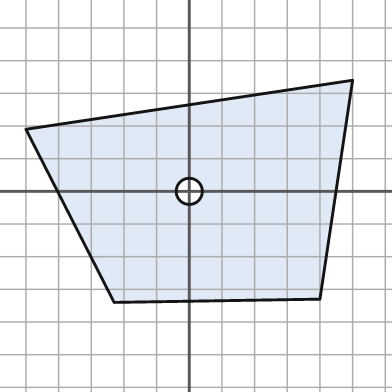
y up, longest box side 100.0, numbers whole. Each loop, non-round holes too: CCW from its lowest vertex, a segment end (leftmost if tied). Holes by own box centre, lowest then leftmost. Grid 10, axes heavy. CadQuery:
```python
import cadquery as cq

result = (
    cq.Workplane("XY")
    .moveTo(-23.0, -34.0)
    .lineTo(40.0, -33.0)
    .lineTo(50.0, 34.0)
    .lineTo(-50.0, 19.0)
    .close()
    .moveTo(0.0, 0.0)
    .circle(4.0)
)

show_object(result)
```